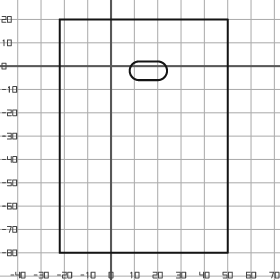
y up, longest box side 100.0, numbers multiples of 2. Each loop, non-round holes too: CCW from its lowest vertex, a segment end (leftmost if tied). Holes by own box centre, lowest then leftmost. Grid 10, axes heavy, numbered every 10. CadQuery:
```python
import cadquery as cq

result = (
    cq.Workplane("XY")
    .moveTo(-22.0, -80.0)
    .lineTo(50.0, -80.0)
    .lineTo(50.0, 20.0)
    .lineTo(-22.0, 20.0)
    .close()
    .moveTo(12.0, -6.0)
    .lineTo(20.0, -6.0)
    .threePointArc((24.0, -2.0), (20.0, 2.0))
    .lineTo(12.0, 2.0)
    .threePointArc((8.0, -2.0), (12.0, -6.0))
    .close()
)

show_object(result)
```